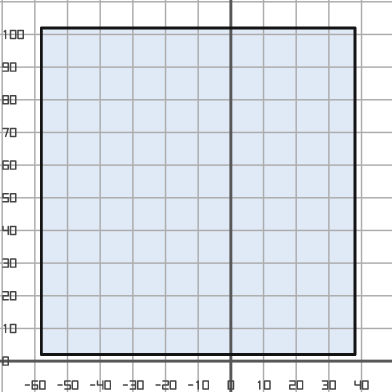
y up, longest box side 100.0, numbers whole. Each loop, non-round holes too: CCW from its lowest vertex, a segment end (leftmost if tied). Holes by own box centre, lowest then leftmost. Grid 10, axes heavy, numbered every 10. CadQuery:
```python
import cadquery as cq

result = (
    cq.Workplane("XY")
    .moveTo(-58.0, 2.0)
    .lineTo(38.0, 2.0)
    .lineTo(38.0, 102.0)
    .lineTo(-58.0, 102.0)
    .close()
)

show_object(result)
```